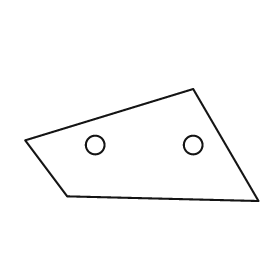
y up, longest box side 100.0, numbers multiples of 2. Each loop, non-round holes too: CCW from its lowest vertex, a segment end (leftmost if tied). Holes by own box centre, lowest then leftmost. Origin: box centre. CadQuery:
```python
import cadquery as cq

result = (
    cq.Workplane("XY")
    .moveTo(50.0, -24.0)
    .lineTo(22.0, 24.0)
    .lineTo(-50.0, 2.0)
    .lineTo(-32.0, -22.0)
    .close()
    .moveTo(-20.0, 0.0)
    .circle(4.0)
    .moveTo(22.0, 0.0)
    .circle(4.0)
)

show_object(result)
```